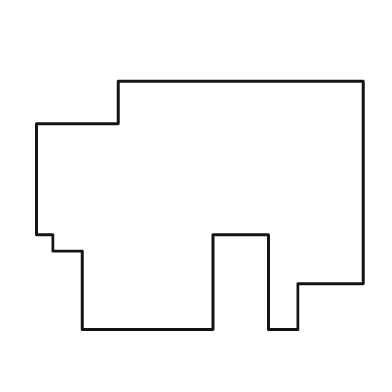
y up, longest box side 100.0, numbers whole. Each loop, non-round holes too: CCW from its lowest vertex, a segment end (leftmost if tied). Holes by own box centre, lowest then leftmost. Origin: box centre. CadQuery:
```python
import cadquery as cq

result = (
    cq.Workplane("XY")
    .moveTo(-36.0, -38.0)
    .lineTo(4.0, -38.0)
    .lineTo(4.0, -9.0)
    .lineTo(21.0, -9.0)
    .lineTo(21.0, -38.0)
    .lineTo(30.0, -38.0)
    .lineTo(30.0, -24.0)
    .lineTo(50.0, -24.0)
    .lineTo(50.0, 38.0)
    .lineTo(-25.0, 38.0)
    .lineTo(-25.0, 25.0)
    .lineTo(-50.0, 25.0)
    .lineTo(-50.0, -9.0)
    .lineTo(-45.0, -9.0)
    .lineTo(-45.0, -14.0)
    .lineTo(-36.0, -14.0)
    .close()
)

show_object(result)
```